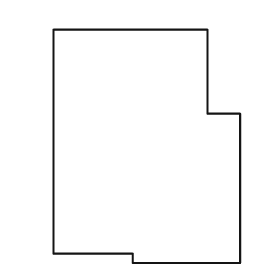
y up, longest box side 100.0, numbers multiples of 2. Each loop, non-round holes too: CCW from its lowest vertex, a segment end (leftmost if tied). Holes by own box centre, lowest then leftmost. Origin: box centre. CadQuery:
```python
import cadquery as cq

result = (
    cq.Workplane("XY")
    .moveTo(-6.0, -50.0)
    .lineTo(40.0, -50.0)
    .lineTo(40.0, 14.0)
    .lineTo(26.0, 14.0)
    .lineTo(26.0, 50.0)
    .lineTo(-40.0, 50.0)
    .lineTo(-40.0, -46.0)
    .lineTo(-6.0, -46.0)
    .close()
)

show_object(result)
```